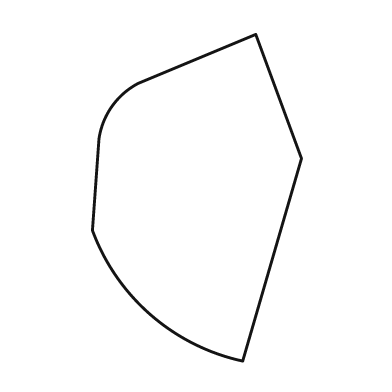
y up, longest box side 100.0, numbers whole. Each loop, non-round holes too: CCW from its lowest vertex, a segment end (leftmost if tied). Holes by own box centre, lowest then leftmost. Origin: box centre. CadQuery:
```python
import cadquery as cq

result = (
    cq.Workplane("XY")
    .moveTo(14.0, -50.0)
    .lineTo(32.0, 12.0)
    .lineTo(18.0, 50.0)
    .lineTo(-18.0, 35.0)
    .threePointArc((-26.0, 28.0), (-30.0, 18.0))
    .lineTo(-32.0, -10.0)
    .threePointArc((-14.0, -36.0), (14.0, -50.0))
    .close()
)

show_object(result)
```